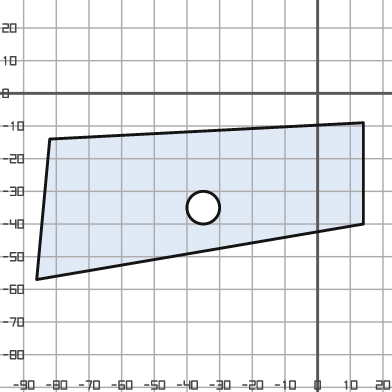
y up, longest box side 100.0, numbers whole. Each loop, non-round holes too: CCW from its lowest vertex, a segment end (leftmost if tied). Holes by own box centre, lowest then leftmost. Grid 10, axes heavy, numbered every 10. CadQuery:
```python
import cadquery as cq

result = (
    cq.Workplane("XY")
    .moveTo(-86.0, -57.0)
    .lineTo(14.0, -40.0)
    .lineTo(14.0, -9.0)
    .lineTo(-82.0, -14.0)
    .close()
    .moveTo(-35.0, -35.0)
    .circle(5.0)
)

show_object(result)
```